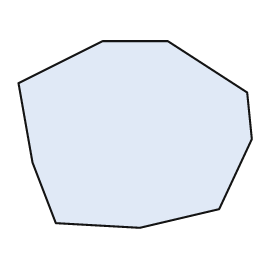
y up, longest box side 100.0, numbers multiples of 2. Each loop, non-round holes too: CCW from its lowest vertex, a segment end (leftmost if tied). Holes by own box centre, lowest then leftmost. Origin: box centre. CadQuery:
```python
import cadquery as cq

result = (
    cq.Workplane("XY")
    .moveTo(2.0, -40.0)
    .lineTo(36.0, -32.0)
    .lineTo(50.0, -2.0)
    .lineTo(48.0, 18.0)
    .lineTo(14.0, 40.0)
    .lineTo(-14.0, 40.0)
    .lineTo(-50.0, 22.0)
    .lineTo(-44.0, -12.0)
    .lineTo(-34.0, -38.0)
    .close()
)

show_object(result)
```